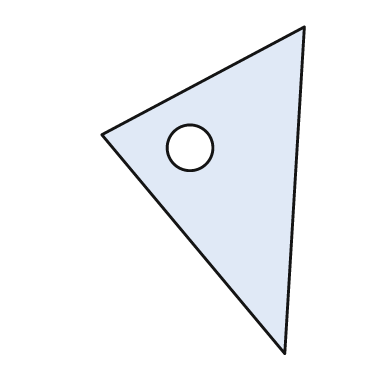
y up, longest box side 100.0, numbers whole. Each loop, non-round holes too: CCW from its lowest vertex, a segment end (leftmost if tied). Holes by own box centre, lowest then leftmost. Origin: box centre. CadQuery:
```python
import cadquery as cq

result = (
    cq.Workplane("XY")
    .moveTo(25.0, -50.0)
    .lineTo(31.0, 50.0)
    .lineTo(-31.0, 17.0)
    .close()
    .moveTo(-4.0, 13.0)
    .circle(7.0)
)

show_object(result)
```